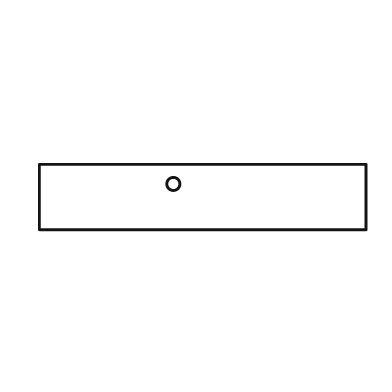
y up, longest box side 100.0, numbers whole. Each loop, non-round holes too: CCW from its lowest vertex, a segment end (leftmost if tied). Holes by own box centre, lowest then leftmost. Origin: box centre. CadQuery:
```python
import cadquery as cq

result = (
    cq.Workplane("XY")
    .moveTo(-50.0, -10.0)
    .lineTo(50.0, -10.0)
    .lineTo(50.0, 10.0)
    .lineTo(-50.0, 10.0)
    .close()
    .moveTo(-9.0, 4.0)
    .circle(2.0)
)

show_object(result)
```